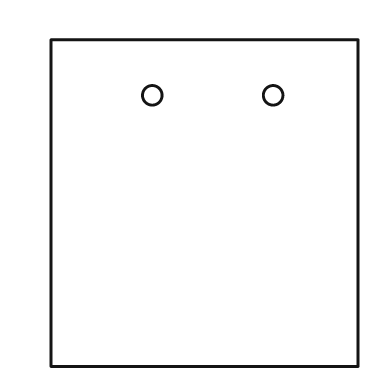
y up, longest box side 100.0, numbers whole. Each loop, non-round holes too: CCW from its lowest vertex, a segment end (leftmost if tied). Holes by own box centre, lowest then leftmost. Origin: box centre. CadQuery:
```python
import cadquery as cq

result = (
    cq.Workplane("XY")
    .moveTo(-47.0, -50.0)
    .lineTo(47.0, -50.0)
    .lineTo(47.0, 50.0)
    .lineTo(-47.0, 50.0)
    .close()
    .moveTo(-16.0, 33.0)
    .circle(3.0)
    .moveTo(21.0, 33.0)
    .circle(3.0)
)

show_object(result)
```